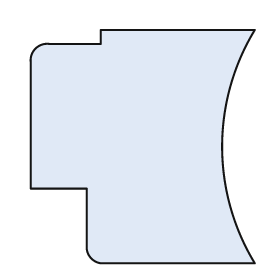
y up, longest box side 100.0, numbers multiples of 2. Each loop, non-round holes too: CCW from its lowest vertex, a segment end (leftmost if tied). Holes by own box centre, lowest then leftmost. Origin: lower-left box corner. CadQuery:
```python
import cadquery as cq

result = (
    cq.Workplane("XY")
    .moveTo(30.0, 0.0)
    .lineTo(96.0, 0.0)
    .threePointArc((82.0, 50.0), (96.0, 100.0))
    .lineTo(30.0, 100.0)
    .lineTo(30.0, 94.0)
    .lineTo(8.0, 94.0)
    .threePointArc((2.0, 92.0), (0.0, 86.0))
    .lineTo(0.0, 32.0)
    .lineTo(24.0, 32.0)
    .lineTo(24.0, 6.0)
    .threePointArc((26.0, 2.0), (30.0, 0.0))
    .close()
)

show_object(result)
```